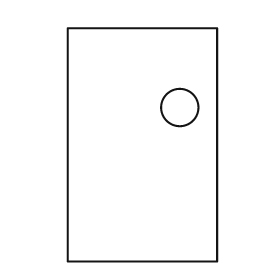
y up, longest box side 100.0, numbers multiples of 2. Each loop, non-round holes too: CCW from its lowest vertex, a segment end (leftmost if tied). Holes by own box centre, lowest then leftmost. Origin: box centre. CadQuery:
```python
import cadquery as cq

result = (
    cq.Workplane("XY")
    .moveTo(-32.0, -50.0)
    .lineTo(32.0, -50.0)
    .lineTo(32.0, 50.0)
    .lineTo(-32.0, 50.0)
    .close()
    .moveTo(16.0, 16.0)
    .circle(8.0)
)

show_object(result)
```